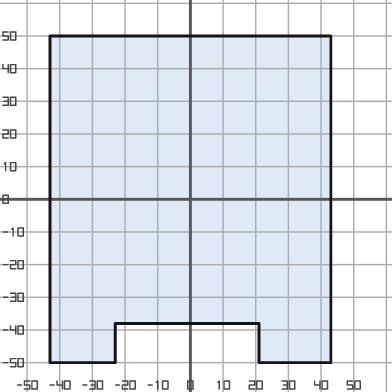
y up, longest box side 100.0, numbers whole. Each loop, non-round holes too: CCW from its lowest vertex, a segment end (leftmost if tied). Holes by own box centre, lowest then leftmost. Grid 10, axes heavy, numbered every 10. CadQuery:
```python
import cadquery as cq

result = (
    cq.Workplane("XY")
    .moveTo(-43.0, -50.0)
    .lineTo(-23.0, -50.0)
    .lineTo(-23.0, -38.0)
    .lineTo(21.0, -38.0)
    .lineTo(21.0, -50.0)
    .lineTo(43.0, -50.0)
    .lineTo(43.0, 50.0)
    .lineTo(-43.0, 50.0)
    .close()
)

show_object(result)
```